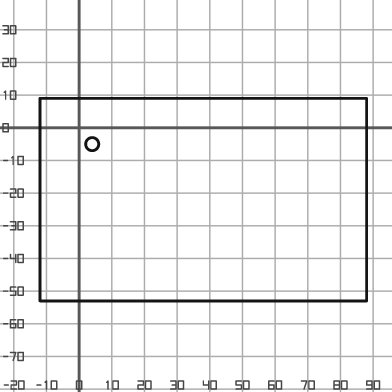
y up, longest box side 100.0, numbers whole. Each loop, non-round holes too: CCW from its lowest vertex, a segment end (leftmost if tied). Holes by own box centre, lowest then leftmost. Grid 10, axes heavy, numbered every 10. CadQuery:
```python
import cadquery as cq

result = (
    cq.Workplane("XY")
    .moveTo(-12.0, -53.0)
    .lineTo(88.0, -53.0)
    .lineTo(88.0, 9.0)
    .lineTo(-12.0, 9.0)
    .close()
    .moveTo(4.0, -5.0)
    .circle(2.0)
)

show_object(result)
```